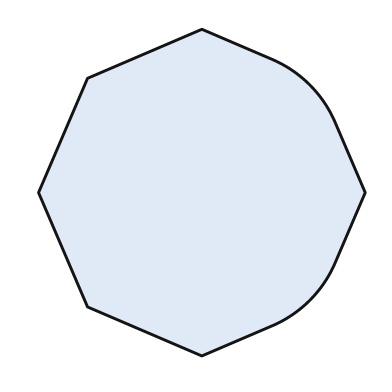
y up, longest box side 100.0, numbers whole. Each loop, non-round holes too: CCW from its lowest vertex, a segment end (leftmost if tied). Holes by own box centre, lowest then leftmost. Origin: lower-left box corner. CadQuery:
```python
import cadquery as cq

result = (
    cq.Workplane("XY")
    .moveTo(50.0, 0.0)
    .lineTo(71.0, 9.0)
    .threePointArc((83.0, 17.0), (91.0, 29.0))
    .lineTo(100.0, 50.0)
    .lineTo(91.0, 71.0)
    .threePointArc((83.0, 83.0), (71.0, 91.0))
    .lineTo(50.0, 100.0)
    .lineTo(15.0, 85.0)
    .lineTo(0.0, 50.0)
    .lineTo(15.0, 15.0)
    .close()
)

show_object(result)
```